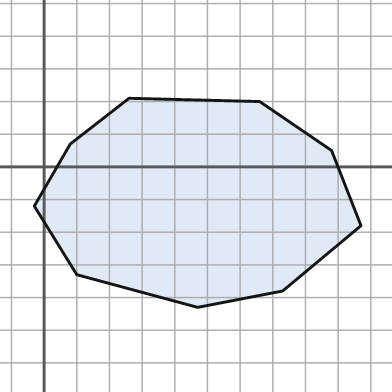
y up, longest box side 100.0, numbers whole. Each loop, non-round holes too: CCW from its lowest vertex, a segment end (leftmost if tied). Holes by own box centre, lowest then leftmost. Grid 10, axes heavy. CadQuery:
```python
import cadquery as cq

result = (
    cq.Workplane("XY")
    .moveTo(47.0, -43.0)
    .lineTo(73.0, -38.0)
    .lineTo(97.0, -18.0)
    .lineTo(88.0, 5.0)
    .lineTo(66.0, 20.0)
    .lineTo(26.0, 21.0)
    .lineTo(8.0, 7.0)
    .lineTo(-3.0, -12.0)
    .lineTo(10.0, -33.0)
    .close()
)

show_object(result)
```